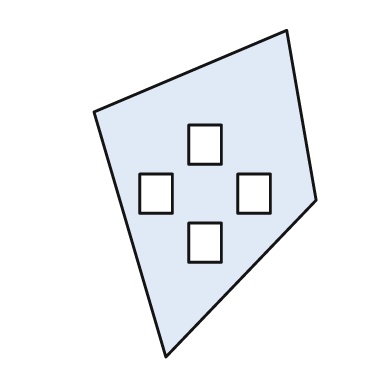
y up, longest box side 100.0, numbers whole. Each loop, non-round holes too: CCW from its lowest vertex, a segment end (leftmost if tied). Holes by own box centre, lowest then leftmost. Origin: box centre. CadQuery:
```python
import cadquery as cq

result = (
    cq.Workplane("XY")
    .moveTo(-12.0, -50.0)
    .lineTo(34.0, -2.0)
    .lineTo(25.0, 50.0)
    .lineTo(-34.0, 25.0)
    .close()
    .moveTo(-5.0, -21.0)
    .lineTo(5.0, -21.0)
    .lineTo(5.0, -9.0)
    .lineTo(-5.0, -9.0)
    .close()
    .moveTo(-20.0, -6.0)
    .lineTo(-10.0, -6.0)
    .lineTo(-10.0, 6.0)
    .lineTo(-20.0, 6.0)
    .close()
    .moveTo(10.0, -6.0)
    .lineTo(20.0, -6.0)
    .lineTo(20.0, 6.0)
    .lineTo(10.0, 6.0)
    .close()
    .moveTo(-5.0, 9.0)
    .lineTo(5.0, 9.0)
    .lineTo(5.0, 21.0)
    .lineTo(-5.0, 21.0)
    .close()
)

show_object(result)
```